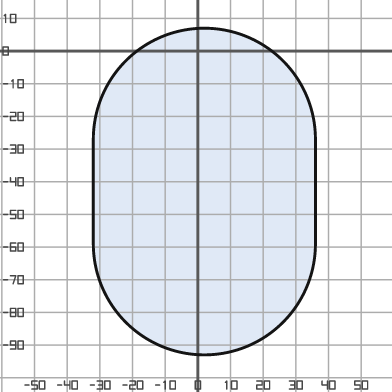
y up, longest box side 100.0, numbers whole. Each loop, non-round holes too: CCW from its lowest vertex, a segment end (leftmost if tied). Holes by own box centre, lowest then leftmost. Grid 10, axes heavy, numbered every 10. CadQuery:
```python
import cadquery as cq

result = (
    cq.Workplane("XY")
    .moveTo(-32.0, -59.0)
    .threePointArc((2.0, -93.0), (36.0, -59.0))
    .lineTo(36.0, -27.0)
    .threePointArc((2.0, 7.0), (-32.0, -27.0))
    .close()
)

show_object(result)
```